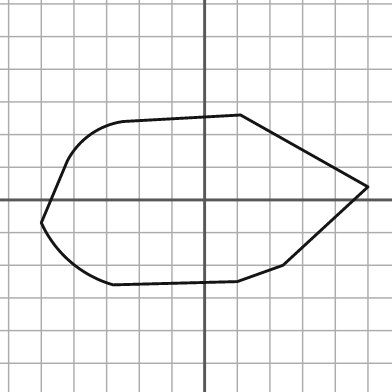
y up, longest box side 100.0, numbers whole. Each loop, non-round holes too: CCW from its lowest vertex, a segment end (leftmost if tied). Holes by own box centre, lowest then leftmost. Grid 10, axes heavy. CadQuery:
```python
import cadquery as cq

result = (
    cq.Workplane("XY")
    .moveTo(-28.0, -26.0)
    .lineTo(10.0, -25.0)
    .lineTo(24.0, -20.0)
    .lineTo(50.0, 4.0)
    .lineTo(11.0, 26.0)
    .lineTo(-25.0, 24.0)
    .threePointArc((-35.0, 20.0), (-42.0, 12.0))
    .lineTo(-50.0, -7.0)
    .threePointArc((-41.0, -19.0), (-28.0, -26.0))
    .close()
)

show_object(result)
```